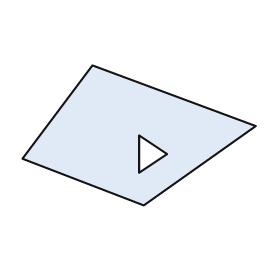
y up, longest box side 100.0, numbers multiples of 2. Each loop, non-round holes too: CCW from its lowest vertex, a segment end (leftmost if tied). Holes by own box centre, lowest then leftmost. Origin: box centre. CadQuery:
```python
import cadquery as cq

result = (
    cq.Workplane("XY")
    .moveTo(2.0, -30.0)
    .lineTo(50.0, 4.0)
    .lineTo(-20.0, 30.0)
    .lineTo(-50.0, -10.0)
    .close()
    .moveTo(0.0, -16.0)
    .lineTo(12.0, -8.0)
    .lineTo(0.0, 0.0)
    .close()
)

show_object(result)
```